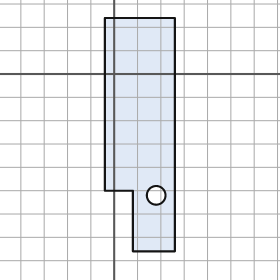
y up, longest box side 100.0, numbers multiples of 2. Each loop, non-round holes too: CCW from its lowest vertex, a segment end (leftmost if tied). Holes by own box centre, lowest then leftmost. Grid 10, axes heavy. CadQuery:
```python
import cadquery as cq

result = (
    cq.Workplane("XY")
    .moveTo(8.0, -76.0)
    .lineTo(26.0, -76.0)
    .lineTo(26.0, 24.0)
    .lineTo(-4.0, 24.0)
    .lineTo(-4.0, -50.0)
    .lineTo(8.0, -50.0)
    .close()
    .moveTo(18.0, -52.0)
    .circle(4.0)
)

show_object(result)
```